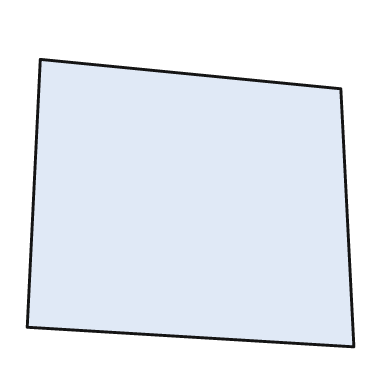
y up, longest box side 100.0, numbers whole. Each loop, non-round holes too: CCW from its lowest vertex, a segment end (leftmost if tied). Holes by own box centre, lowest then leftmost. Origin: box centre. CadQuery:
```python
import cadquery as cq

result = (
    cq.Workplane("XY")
    .moveTo(50.0, -44.0)
    .lineTo(46.0, 35.0)
    .lineTo(-46.0, 44.0)
    .lineTo(-50.0, -38.0)
    .close()
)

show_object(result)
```